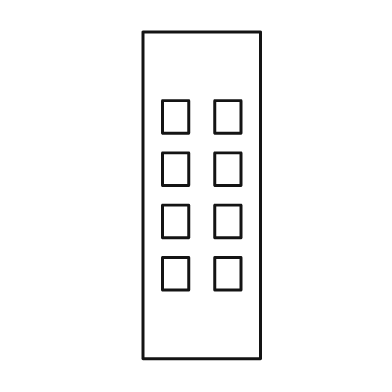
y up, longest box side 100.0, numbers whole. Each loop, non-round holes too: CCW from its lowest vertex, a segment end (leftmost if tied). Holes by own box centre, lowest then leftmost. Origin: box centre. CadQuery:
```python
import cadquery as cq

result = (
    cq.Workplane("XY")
    .moveTo(-18.0, -50.0)
    .lineTo(18.0, -50.0)
    .lineTo(18.0, 50.0)
    .lineTo(-18.0, 50.0)
    .close()
    .moveTo(-12.0, -29.0)
    .lineTo(-4.0, -29.0)
    .lineTo(-4.0, -19.0)
    .lineTo(-12.0, -19.0)
    .close()
    .moveTo(4.0, -29.0)
    .lineTo(12.0, -29.0)
    .lineTo(12.0, -19.0)
    .lineTo(4.0, -19.0)
    .close()
    .moveTo(-12.0, -13.0)
    .lineTo(-4.0, -13.0)
    .lineTo(-4.0, -3.0)
    .lineTo(-12.0, -3.0)
    .close()
    .moveTo(4.0, -13.0)
    .lineTo(12.0, -13.0)
    .lineTo(12.0, -3.0)
    .lineTo(4.0, -3.0)
    .close()
    .moveTo(-12.0, 3.0)
    .lineTo(-4.0, 3.0)
    .lineTo(-4.0, 13.0)
    .lineTo(-12.0, 13.0)
    .close()
    .moveTo(4.0, 3.0)
    .lineTo(12.0, 3.0)
    .lineTo(12.0, 13.0)
    .lineTo(4.0, 13.0)
    .close()
    .moveTo(-12.0, 19.0)
    .lineTo(-4.0, 19.0)
    .lineTo(-4.0, 29.0)
    .lineTo(-12.0, 29.0)
    .close()
    .moveTo(4.0, 19.0)
    .lineTo(12.0, 19.0)
    .lineTo(12.0, 29.0)
    .lineTo(4.0, 29.0)
    .close()
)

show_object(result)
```